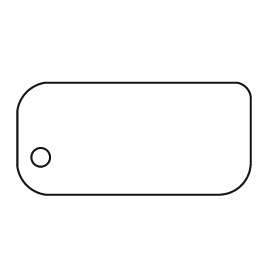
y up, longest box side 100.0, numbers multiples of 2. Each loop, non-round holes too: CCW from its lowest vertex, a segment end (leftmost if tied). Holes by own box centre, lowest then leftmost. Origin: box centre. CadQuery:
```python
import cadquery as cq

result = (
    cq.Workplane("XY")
    .moveTo(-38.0, -24.0)
    .lineTo(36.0, -24.0)
    .threePointArc((46.0, -20.0), (50.0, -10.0))
    .lineTo(50.0, 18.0)
    .threePointArc((48.0, 22.0), (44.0, 24.0))
    .lineTo(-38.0, 24.0)
    .threePointArc((-46.0, 20.0), (-50.0, 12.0))
    .lineTo(-50.0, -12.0)
    .threePointArc((-46.0, -20.0), (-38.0, -24.0))
    .close()
    .moveTo(-40.0, -8.0)
    .circle(4.0)
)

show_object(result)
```